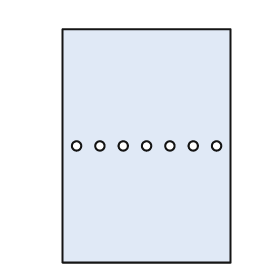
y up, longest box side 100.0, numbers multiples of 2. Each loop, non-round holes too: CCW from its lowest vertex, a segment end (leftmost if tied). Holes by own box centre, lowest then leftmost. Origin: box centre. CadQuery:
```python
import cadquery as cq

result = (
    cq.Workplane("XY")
    .moveTo(-36.0, -50.0)
    .lineTo(36.0, -50.0)
    .lineTo(36.0, 50.0)
    .lineTo(-36.0, 50.0)
    .close()
    .moveTo(-30.0, 0.0)
    .circle(2.0)
    .moveTo(-20.0, 0.0)
    .circle(2.0)
    .moveTo(-10.0, 0.0)
    .circle(2.0)
    .moveTo(0.0, 0.0)
    .circle(2.0)
    .moveTo(10.0, 0.0)
    .circle(2.0)
    .moveTo(20.0, 0.0)
    .circle(2.0)
    .moveTo(30.0, 0.0)
    .circle(2.0)
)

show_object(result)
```